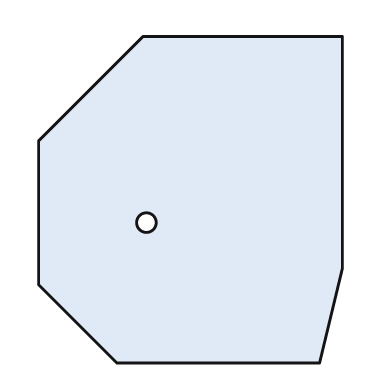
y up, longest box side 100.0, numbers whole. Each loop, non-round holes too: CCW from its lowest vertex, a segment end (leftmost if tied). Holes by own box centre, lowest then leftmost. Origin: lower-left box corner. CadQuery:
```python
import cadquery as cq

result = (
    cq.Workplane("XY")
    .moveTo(24.0, 0.0)
    .lineTo(86.0, 0.0)
    .lineTo(93.0, 29.0)
    .lineTo(93.0, 100.0)
    .lineTo(32.0, 100.0)
    .lineTo(0.0, 68.0)
    .lineTo(0.0, 24.0)
    .close()
    .moveTo(33.0, 43.0)
    .circle(3.0)
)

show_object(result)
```